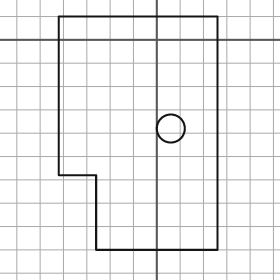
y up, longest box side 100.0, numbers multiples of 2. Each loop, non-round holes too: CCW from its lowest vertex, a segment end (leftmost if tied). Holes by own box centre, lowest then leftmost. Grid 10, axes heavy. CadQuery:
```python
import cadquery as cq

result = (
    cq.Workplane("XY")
    .moveTo(-26.0, -90.0)
    .lineTo(26.0, -90.0)
    .lineTo(26.0, 10.0)
    .lineTo(-42.0, 10.0)
    .lineTo(-42.0, -58.0)
    .lineTo(-26.0, -58.0)
    .close()
    .moveTo(6.0, -38.0)
    .circle(6.0)
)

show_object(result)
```